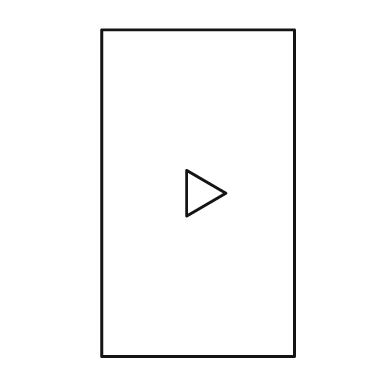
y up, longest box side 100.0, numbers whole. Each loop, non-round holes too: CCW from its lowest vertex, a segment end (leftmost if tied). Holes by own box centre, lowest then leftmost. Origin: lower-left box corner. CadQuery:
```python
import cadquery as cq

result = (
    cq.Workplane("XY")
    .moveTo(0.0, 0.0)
    .lineTo(59.0, 0.0)
    .lineTo(59.0, 100.0)
    .lineTo(0.0, 100.0)
    .close()
    .moveTo(26.0, 43.0)
    .lineTo(38.0, 50.0)
    .lineTo(26.0, 57.0)
    .close()
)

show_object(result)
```